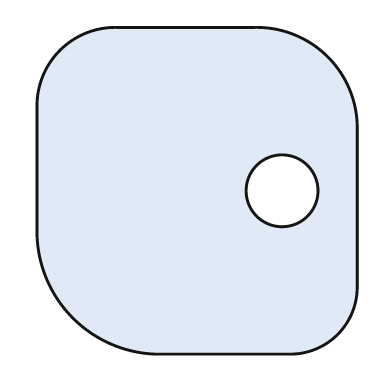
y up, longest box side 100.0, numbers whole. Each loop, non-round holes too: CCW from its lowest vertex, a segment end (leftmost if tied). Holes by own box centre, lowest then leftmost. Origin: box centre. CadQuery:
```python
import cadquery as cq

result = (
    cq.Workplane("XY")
    .moveTo(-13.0, -50.0)
    .lineTo(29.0, -50.0)
    .threePointArc((43.0, -44.0), (49.0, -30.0))
    .lineTo(49.0, 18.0)
    .threePointArc((40.0, 41.0), (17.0, 50.0))
    .lineTo(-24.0, 50.0)
    .threePointArc((-42.0, 43.0), (-49.0, 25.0))
    .lineTo(-49.0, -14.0)
    .threePointArc((-38.0, -39.0), (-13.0, -50.0))
    .close()
    .moveTo(26.0, 0.0)
    .circle(11.0)
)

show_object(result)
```